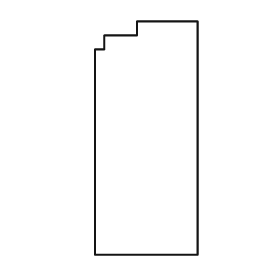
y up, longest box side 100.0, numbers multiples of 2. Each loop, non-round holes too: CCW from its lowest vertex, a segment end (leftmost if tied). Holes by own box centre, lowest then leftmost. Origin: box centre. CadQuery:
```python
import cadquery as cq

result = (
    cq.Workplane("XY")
    .moveTo(-22.0, -50.0)
    .lineTo(22.0, -50.0)
    .lineTo(22.0, 50.0)
    .lineTo(-4.0, 50.0)
    .lineTo(-4.0, 44.0)
    .lineTo(-18.0, 44.0)
    .lineTo(-18.0, 38.0)
    .lineTo(-22.0, 38.0)
    .close()
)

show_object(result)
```